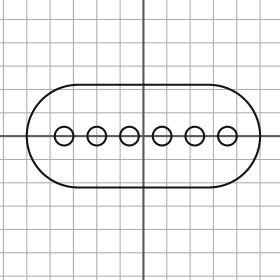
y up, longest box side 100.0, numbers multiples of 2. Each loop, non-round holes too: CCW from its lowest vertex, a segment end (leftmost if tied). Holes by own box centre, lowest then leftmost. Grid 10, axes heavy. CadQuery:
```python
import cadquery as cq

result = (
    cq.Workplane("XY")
    .moveTo(-28.0, -22.0)
    .lineTo(28.0, -22.0)
    .threePointArc((50.0, 0.0), (28.0, 22.0))
    .lineTo(-28.0, 22.0)
    .threePointArc((-50.0, 0.0), (-28.0, -22.0))
    .close()
    .moveTo(-34.0, 0.0)
    .circle(4.0)
    .moveTo(-20.0, 0.0)
    .circle(4.0)
    .moveTo(-6.0, 0.0)
    .circle(4.0)
    .moveTo(8.0, 0.0)
    .circle(4.0)
    .moveTo(22.0, 0.0)
    .circle(4.0)
    .moveTo(36.0, 0.0)
    .circle(4.0)
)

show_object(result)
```